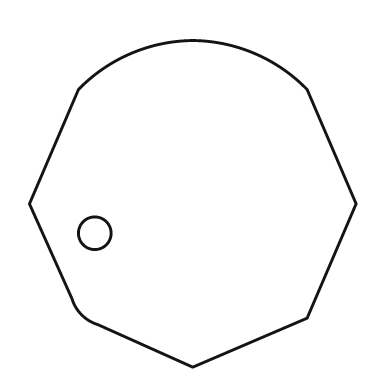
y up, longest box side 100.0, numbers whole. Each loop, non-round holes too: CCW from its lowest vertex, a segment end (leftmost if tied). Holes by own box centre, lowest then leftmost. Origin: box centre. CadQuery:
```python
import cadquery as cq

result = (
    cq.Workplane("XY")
    .moveTo(0.0, -50.0)
    .lineTo(35.0, -35.0)
    .lineTo(50.0, 0.0)
    .lineTo(35.0, 35.0)
    .threePointArc((19.0, 46.0), (0.0, 50.0))
    .threePointArc((-19.0, 46.0), (-35.0, 35.0))
    .lineTo(-50.0, 0.0)
    .lineTo(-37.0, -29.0)
    .threePointArc((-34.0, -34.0), (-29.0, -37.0))
    .close()
    .moveTo(-30.0, -9.0)
    .circle(5.0)
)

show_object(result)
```